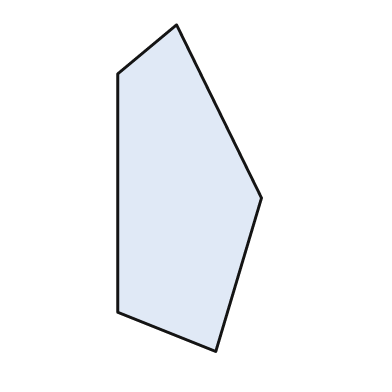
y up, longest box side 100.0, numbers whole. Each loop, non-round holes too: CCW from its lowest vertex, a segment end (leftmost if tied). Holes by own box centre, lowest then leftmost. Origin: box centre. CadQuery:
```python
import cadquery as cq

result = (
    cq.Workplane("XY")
    .moveTo(8.0, -50.0)
    .lineTo(22.0, -3.0)
    .lineTo(-4.0, 50.0)
    .lineTo(-22.0, 35.0)
    .lineTo(-22.0, -38.0)
    .close()
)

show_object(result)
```